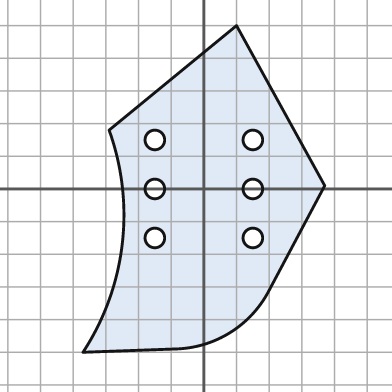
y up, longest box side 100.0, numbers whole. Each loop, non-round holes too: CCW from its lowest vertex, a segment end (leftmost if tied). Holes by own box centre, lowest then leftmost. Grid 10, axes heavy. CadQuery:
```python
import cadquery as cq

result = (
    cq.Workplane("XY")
    .moveTo(-37.0, -50.0)
    .lineTo(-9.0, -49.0)
    .threePointArc((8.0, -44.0), (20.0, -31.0))
    .lineTo(37.0, 1.0)
    .lineTo(10.0, 50.0)
    .lineTo(-29.0, 18.0)
    .threePointArc((-25.0, -17.0), (-37.0, -50.0))
    .close()
    .moveTo(-15.0, -15.0)
    .circle(3.0)
    .moveTo(15.0, -15.0)
    .circle(3.0)
    .moveTo(-15.0, 0.0)
    .circle(3.0)
    .moveTo(15.0, 0.0)
    .circle(3.0)
    .moveTo(-15.0, 15.0)
    .circle(3.0)
    .moveTo(15.0, 15.0)
    .circle(3.0)
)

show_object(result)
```